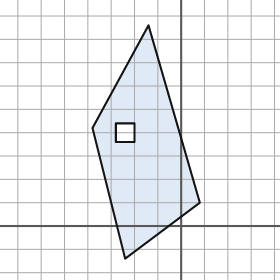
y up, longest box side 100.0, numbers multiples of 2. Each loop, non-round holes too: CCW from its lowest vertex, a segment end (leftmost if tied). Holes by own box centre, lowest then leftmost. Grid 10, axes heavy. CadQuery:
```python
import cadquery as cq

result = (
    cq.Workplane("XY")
    .moveTo(-24.0, -14.0)
    .lineTo(8.0, 10.0)
    .lineTo(-14.0, 86.0)
    .lineTo(-38.0, 42.0)
    .close()
    .moveTo(-28.0, 36.0)
    .lineTo(-20.0, 36.0)
    .lineTo(-20.0, 44.0)
    .lineTo(-28.0, 44.0)
    .close()
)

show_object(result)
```